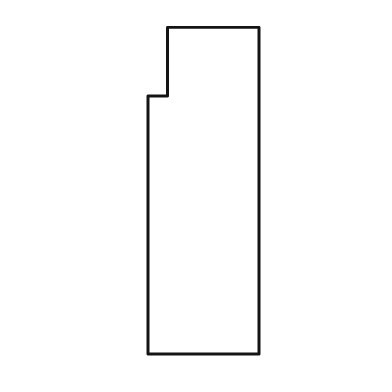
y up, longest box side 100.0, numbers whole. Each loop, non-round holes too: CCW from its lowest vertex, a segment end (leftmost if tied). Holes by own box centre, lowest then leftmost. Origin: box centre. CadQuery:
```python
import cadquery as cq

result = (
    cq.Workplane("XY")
    .moveTo(-17.0, -50.0)
    .lineTo(17.0, -50.0)
    .lineTo(17.0, 50.0)
    .lineTo(-11.0, 50.0)
    .lineTo(-11.0, 29.0)
    .lineTo(-17.0, 29.0)
    .close()
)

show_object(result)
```